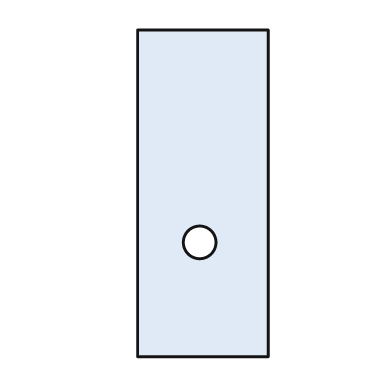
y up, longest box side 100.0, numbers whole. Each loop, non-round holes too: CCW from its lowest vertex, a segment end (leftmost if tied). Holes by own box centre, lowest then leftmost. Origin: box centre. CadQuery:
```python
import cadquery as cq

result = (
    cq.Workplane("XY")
    .moveTo(-20.0, -50.0)
    .lineTo(20.0, -50.0)
    .lineTo(20.0, 50.0)
    .lineTo(-20.0, 50.0)
    .close()
    .moveTo(-1.0, -15.0)
    .circle(5.0)
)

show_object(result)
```